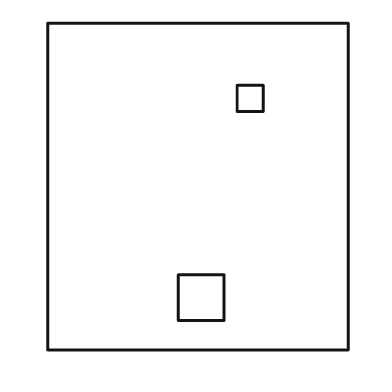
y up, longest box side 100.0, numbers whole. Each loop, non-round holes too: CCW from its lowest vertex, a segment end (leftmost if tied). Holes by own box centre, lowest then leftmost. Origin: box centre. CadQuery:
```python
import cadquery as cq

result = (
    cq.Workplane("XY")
    .moveTo(-46.0, -50.0)
    .lineTo(46.0, -50.0)
    .lineTo(46.0, 50.0)
    .lineTo(-46.0, 50.0)
    .close()
    .moveTo(-6.0, -41.0)
    .lineTo(8.0, -41.0)
    .lineTo(8.0, -27.0)
    .lineTo(-6.0, -27.0)
    .close()
    .moveTo(12.0, 23.0)
    .lineTo(20.0, 23.0)
    .lineTo(20.0, 31.0)
    .lineTo(12.0, 31.0)
    .close()
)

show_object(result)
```